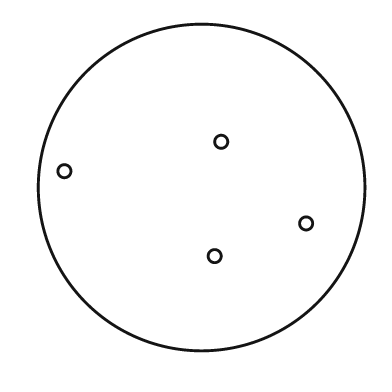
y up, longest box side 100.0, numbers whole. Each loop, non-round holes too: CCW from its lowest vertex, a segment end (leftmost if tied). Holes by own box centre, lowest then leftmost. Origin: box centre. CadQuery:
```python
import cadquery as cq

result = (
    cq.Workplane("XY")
    .moveTo(0.0, 0.0)
    .circle(50.0)
    .moveTo(4.0, -21.0)
    .circle(2.0)
    .moveTo(32.0, -11.0)
    .circle(2.0)
    .moveTo(-42.0, 5.0)
    .circle(2.0)
    .moveTo(6.0, 14.0)
    .circle(2.0)
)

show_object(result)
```